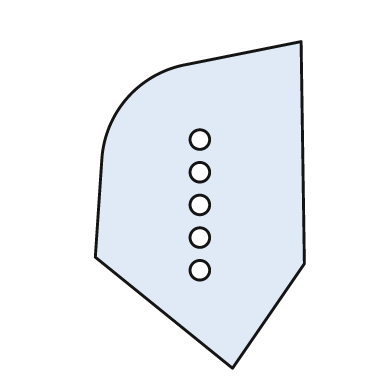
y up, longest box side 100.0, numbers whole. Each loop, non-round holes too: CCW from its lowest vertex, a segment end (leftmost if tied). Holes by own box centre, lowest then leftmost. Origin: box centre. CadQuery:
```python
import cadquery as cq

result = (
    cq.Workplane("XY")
    .moveTo(10.0, -50.0)
    .lineTo(32.0, -18.0)
    .lineTo(31.0, 50.0)
    .lineTo(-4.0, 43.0)
    .threePointArc((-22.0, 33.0), (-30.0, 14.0))
    .lineTo(-32.0, -16.0)
    .close()
    .moveTo(0.0, -20.0)
    .circle(3.0)
    .moveTo(0.0, -10.0)
    .circle(3.0)
    .moveTo(0.0, 0.0)
    .circle(3.0)
    .moveTo(0.0, 10.0)
    .circle(3.0)
    .moveTo(0.0, 20.0)
    .circle(3.0)
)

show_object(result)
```